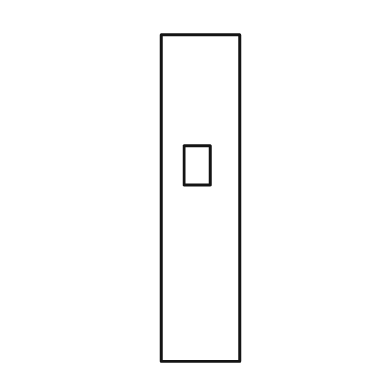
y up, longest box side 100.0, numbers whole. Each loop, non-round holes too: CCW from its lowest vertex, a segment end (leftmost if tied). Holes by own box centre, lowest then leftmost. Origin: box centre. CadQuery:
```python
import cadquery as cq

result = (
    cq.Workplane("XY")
    .moveTo(-12.0, -50.0)
    .lineTo(12.0, -50.0)
    .lineTo(12.0, 50.0)
    .lineTo(-12.0, 50.0)
    .close()
    .moveTo(-5.0, 4.0)
    .lineTo(3.0, 4.0)
    .lineTo(3.0, 16.0)
    .lineTo(-5.0, 16.0)
    .close()
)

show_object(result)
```